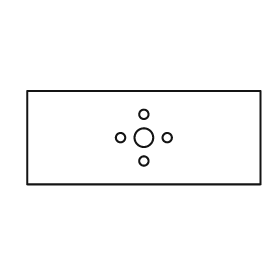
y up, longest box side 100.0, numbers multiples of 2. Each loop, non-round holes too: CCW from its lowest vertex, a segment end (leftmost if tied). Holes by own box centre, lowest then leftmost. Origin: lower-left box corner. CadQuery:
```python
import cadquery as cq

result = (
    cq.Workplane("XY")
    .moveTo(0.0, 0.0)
    .lineTo(100.0, 0.0)
    .lineTo(100.0, 40.0)
    .lineTo(0.0, 40.0)
    .close()
    .moveTo(50.0, 10.0)
    .circle(2.0)
    .moveTo(40.0, 20.0)
    .circle(2.0)
    .moveTo(50.0, 20.0)
    .circle(4.0)
    .moveTo(60.0, 20.0)
    .circle(2.0)
    .moveTo(50.0, 30.0)
    .circle(2.0)
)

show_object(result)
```